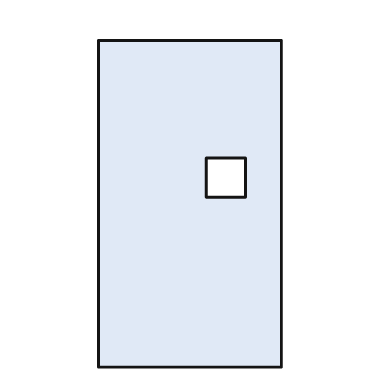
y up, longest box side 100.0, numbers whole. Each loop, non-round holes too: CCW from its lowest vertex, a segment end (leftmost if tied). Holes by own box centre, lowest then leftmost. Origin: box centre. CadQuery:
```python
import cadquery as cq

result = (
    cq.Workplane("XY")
    .moveTo(-28.0, -50.0)
    .lineTo(28.0, -50.0)
    .lineTo(28.0, 50.0)
    .lineTo(-28.0, 50.0)
    .close()
    .moveTo(5.0, 2.0)
    .lineTo(17.0, 2.0)
    .lineTo(17.0, 14.0)
    .lineTo(5.0, 14.0)
    .close()
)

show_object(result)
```